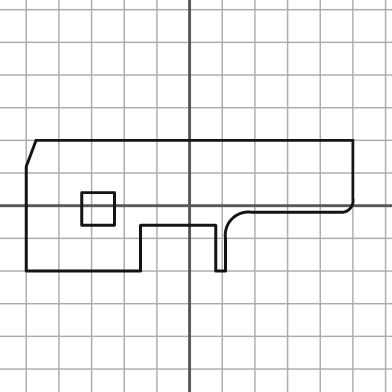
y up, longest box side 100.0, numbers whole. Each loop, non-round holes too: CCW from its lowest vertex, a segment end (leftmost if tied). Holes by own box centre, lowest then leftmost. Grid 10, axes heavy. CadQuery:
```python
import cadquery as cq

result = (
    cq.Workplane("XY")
    .moveTo(-50.0, -20.0)
    .lineTo(-15.0, -20.0)
    .lineTo(-15.0, -6.0)
    .lineTo(8.0, -6.0)
    .lineTo(8.0, -20.0)
    .lineTo(11.0, -20.0)
    .lineTo(11.0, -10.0)
    .threePointArc((13.0, -4.0), (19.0, -2.0))
    .lineTo(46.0, -2.0)
    .threePointArc((49.0, -1.0), (50.0, 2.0))
    .lineTo(50.0, 20.0)
    .lineTo(-47.0, 20.0)
    .lineTo(-50.0, 12.0)
    .close()
    .moveTo(-33.0, -6.0)
    .lineTo(-23.0, -6.0)
    .lineTo(-23.0, 4.0)
    .lineTo(-33.0, 4.0)
    .close()
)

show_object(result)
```